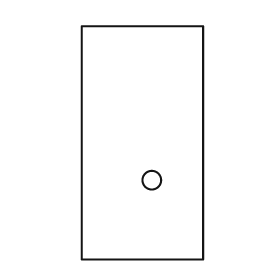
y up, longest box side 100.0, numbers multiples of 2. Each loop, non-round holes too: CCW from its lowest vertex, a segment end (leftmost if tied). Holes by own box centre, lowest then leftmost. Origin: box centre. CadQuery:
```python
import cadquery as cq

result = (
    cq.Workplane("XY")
    .moveTo(-26.0, -50.0)
    .lineTo(26.0, -50.0)
    .lineTo(26.0, 50.0)
    .lineTo(-26.0, 50.0)
    .close()
    .moveTo(4.0, -16.0)
    .circle(4.0)
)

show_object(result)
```